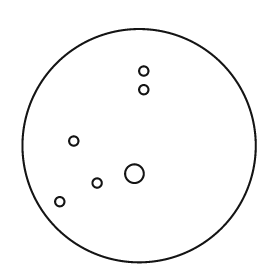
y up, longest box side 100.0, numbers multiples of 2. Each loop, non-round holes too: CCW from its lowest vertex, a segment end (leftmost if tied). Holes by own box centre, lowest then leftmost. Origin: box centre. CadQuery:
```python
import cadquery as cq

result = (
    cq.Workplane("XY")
    .moveTo(0.0, 0.0)
    .circle(50.0)
    .moveTo(-34.0, -24.0)
    .circle(2.0)
    .moveTo(-18.0, -16.0)
    .circle(2.0)
    .moveTo(-2.0, -12.0)
    .circle(4.0)
    .moveTo(-28.0, 2.0)
    .circle(2.0)
    .moveTo(2.0, 24.0)
    .circle(2.0)
    .moveTo(2.0, 32.0)
    .circle(2.0)
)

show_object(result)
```